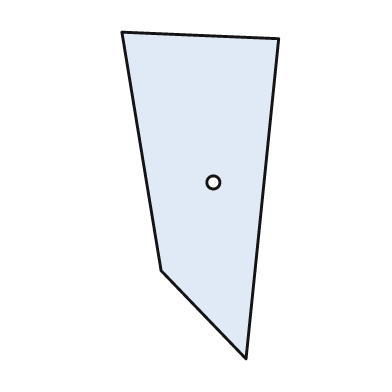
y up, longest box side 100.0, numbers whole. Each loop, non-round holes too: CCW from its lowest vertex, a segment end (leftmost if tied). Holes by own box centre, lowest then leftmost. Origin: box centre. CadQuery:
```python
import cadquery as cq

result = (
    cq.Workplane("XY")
    .moveTo(14.0, -50.0)
    .lineTo(24.0, 48.0)
    .lineTo(-24.0, 50.0)
    .lineTo(-12.0, -23.0)
    .close()
    .moveTo(4.0, 4.0)
    .circle(2.0)
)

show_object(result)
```